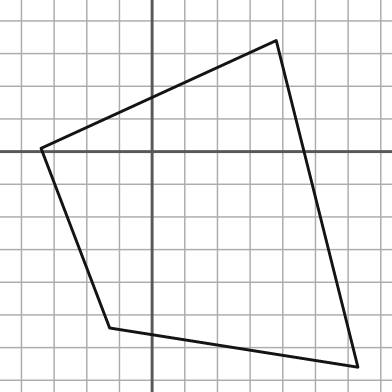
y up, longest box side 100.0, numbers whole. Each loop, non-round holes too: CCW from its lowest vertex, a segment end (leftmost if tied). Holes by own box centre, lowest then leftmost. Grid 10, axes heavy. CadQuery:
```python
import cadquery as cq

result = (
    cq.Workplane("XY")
    .moveTo(63.0, -66.0)
    .lineTo(38.0, 34.0)
    .lineTo(-34.0, 1.0)
    .lineTo(-13.0, -54.0)
    .close()
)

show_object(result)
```